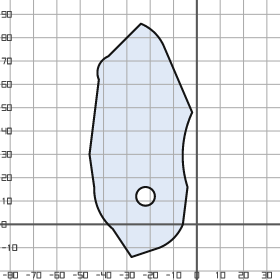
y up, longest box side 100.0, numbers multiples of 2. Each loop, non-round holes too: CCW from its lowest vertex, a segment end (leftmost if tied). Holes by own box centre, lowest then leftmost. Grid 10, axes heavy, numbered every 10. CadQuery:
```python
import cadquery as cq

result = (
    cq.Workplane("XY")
    .moveTo(-28.0, -14.0)
    .lineTo(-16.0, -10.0)
    .threePointArc((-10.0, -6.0), (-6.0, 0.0))
    .lineTo(-4.0, 16.0)
    .threePointArc((-6.0, 32.0), (-2.0, 48.0))
    .lineTo(-14.0, 76.0)
    .threePointArc((-18.0, 82.0), (-24.0, 86.0))
    .lineTo(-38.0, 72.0)
    .threePointArc((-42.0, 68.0), (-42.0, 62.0))
    .lineTo(-46.0, 30.0)
    .lineTo(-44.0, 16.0)
    .threePointArc((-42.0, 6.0), (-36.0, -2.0))
    .close()
    .moveTo(-22.0, 12.0)
    .circle(4.0)
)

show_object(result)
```